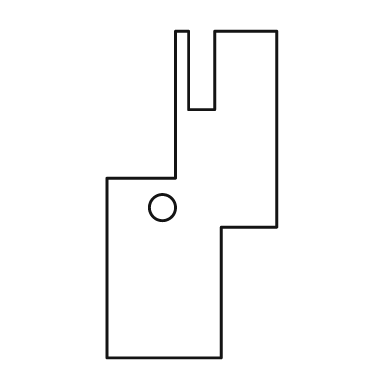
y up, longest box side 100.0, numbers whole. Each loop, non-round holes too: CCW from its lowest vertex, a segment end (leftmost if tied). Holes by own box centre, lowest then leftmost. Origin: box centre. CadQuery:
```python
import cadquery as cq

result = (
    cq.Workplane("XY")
    .moveTo(-26.0, -50.0)
    .lineTo(9.0, -50.0)
    .lineTo(9.0, -10.0)
    .lineTo(26.0, -10.0)
    .lineTo(26.0, 50.0)
    .lineTo(7.0, 50.0)
    .lineTo(7.0, 26.0)
    .lineTo(-1.0, 26.0)
    .lineTo(-1.0, 50.0)
    .lineTo(-5.0, 50.0)
    .lineTo(-5.0, 5.0)
    .lineTo(-26.0, 5.0)
    .close()
    .moveTo(-9.0, -4.0)
    .circle(4.0)
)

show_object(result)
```